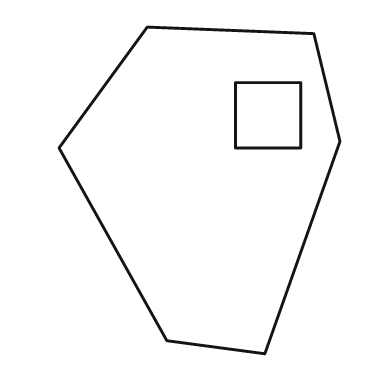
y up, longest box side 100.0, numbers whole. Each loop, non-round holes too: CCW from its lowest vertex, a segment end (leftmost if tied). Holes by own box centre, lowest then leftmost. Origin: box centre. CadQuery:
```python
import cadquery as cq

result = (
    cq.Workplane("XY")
    .moveTo(20.0, -50.0)
    .lineTo(43.0, 15.0)
    .lineTo(35.0, 48.0)
    .lineTo(-16.0, 50.0)
    .lineTo(-43.0, 13.0)
    .lineTo(-10.0, -46.0)
    .close()
    .moveTo(11.0, 13.0)
    .lineTo(31.0, 13.0)
    .lineTo(31.0, 33.0)
    .lineTo(11.0, 33.0)
    .close()
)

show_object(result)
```